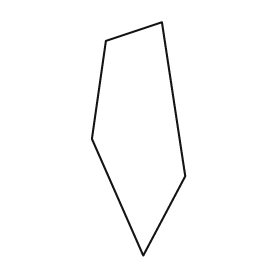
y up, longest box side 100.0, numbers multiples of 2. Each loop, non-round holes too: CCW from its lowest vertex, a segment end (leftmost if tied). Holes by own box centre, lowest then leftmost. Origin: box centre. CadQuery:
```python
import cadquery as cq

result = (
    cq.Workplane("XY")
    .moveTo(2.0, -50.0)
    .lineTo(20.0, -16.0)
    .lineTo(10.0, 50.0)
    .lineTo(-14.0, 42.0)
    .lineTo(-20.0, 0.0)
    .close()
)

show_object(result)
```